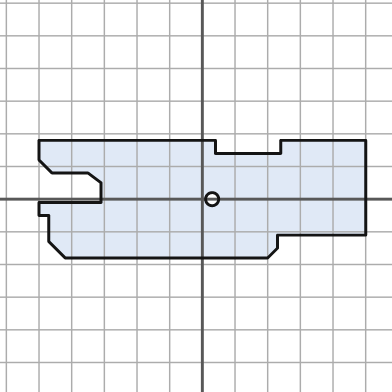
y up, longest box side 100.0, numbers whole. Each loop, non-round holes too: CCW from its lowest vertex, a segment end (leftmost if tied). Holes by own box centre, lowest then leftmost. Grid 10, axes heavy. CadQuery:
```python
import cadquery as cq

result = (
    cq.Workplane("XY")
    .moveTo(-42.0, -18.0)
    .lineTo(20.0, -18.0)
    .lineTo(23.0, -15.0)
    .lineTo(23.0, -11.0)
    .lineTo(50.0, -11.0)
    .lineTo(50.0, 18.0)
    .lineTo(24.0, 18.0)
    .lineTo(24.0, 14.0)
    .lineTo(4.0, 14.0)
    .lineTo(4.0, 18.0)
    .lineTo(-50.0, 18.0)
    .lineTo(-50.0, 12.0)
    .lineTo(-46.0, 8.0)
    .lineTo(-35.0, 8.0)
    .lineTo(-31.0, 5.0)
    .lineTo(-31.0, -1.0)
    .lineTo(-50.0, -1.0)
    .lineTo(-50.0, -5.0)
    .lineTo(-47.0, -5.0)
    .lineTo(-47.0, -13.0)
    .close()
    .moveTo(3.0, 0.0)
    .circle(2.0)
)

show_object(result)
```